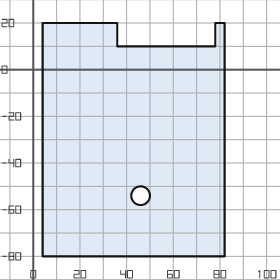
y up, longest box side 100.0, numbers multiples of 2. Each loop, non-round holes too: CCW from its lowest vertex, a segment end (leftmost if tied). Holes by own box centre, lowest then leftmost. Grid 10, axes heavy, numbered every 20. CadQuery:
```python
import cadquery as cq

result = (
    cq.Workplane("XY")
    .moveTo(4.0, -80.0)
    .lineTo(82.0, -80.0)
    .lineTo(82.0, 20.0)
    .lineTo(78.0, 20.0)
    .lineTo(78.0, 10.0)
    .lineTo(36.0, 10.0)
    .lineTo(36.0, 20.0)
    .lineTo(4.0, 20.0)
    .close()
    .moveTo(46.0, -54.0)
    .circle(4.0)
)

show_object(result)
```